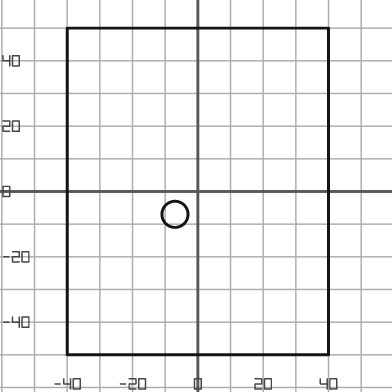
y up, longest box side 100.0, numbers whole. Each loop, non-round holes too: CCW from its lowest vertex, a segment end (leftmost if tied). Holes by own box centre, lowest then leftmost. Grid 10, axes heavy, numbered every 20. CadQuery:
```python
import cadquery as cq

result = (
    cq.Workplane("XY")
    .moveTo(-40.0, -50.0)
    .lineTo(40.0, -50.0)
    .lineTo(40.0, 50.0)
    .lineTo(-40.0, 50.0)
    .close()
    .moveTo(-7.0, -7.0)
    .circle(4.0)
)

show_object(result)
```